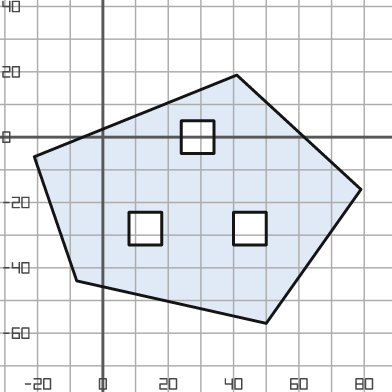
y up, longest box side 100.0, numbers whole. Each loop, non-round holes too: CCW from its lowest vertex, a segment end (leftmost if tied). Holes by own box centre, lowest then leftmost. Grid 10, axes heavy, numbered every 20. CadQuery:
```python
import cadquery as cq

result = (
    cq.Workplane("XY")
    .moveTo(50.0, -57.0)
    .lineTo(79.0, -16.0)
    .lineTo(41.0, 19.0)
    .lineTo(-21.0, -6.0)
    .lineTo(-8.0, -44.0)
    .close()
    .moveTo(8.0, -33.0)
    .lineTo(18.0, -33.0)
    .lineTo(18.0, -23.0)
    .lineTo(8.0, -23.0)
    .close()
    .moveTo(40.0, -33.0)
    .lineTo(50.0, -33.0)
    .lineTo(50.0, -23.0)
    .lineTo(40.0, -23.0)
    .close()
    .moveTo(24.0, -5.0)
    .lineTo(34.0, -5.0)
    .lineTo(34.0, 5.0)
    .lineTo(24.0, 5.0)
    .close()
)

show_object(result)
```